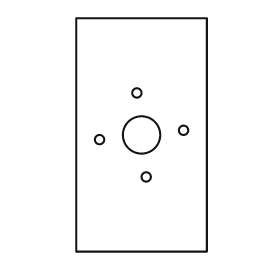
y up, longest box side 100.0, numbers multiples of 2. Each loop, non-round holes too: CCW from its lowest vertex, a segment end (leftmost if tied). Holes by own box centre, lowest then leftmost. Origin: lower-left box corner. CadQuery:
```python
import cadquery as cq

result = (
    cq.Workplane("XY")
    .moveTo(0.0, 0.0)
    .lineTo(56.0, 0.0)
    .lineTo(56.0, 100.0)
    .lineTo(0.0, 100.0)
    .close()
    .moveTo(30.0, 32.0)
    .circle(2.0)
    .moveTo(10.0, 48.0)
    .circle(2.0)
    .moveTo(28.0, 50.0)
    .circle(8.0)
    .moveTo(46.0, 52.0)
    .circle(2.0)
    .moveTo(26.0, 68.0)
    .circle(2.0)
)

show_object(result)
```